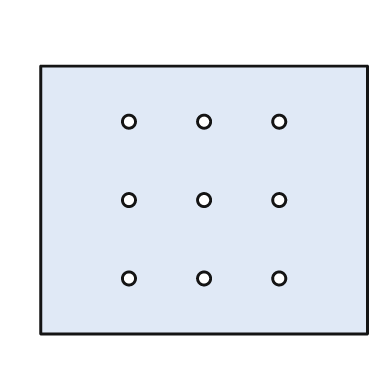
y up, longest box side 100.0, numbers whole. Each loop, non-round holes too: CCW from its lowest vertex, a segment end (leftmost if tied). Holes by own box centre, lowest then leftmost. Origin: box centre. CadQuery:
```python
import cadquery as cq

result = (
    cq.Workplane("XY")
    .moveTo(-50.0, -41.0)
    .lineTo(50.0, -41.0)
    .lineTo(50.0, 41.0)
    .lineTo(-50.0, 41.0)
    .close()
    .moveTo(-23.0, -24.0)
    .circle(2.0)
    .moveTo(0.0, -24.0)
    .circle(2.0)
    .moveTo(23.0, -24.0)
    .circle(2.0)
    .moveTo(-23.0, 0.0)
    .circle(2.0)
    .moveTo(0.0, 0.0)
    .circle(2.0)
    .moveTo(23.0, 0.0)
    .circle(2.0)
    .moveTo(-23.0, 24.0)
    .circle(2.0)
    .moveTo(0.0, 24.0)
    .circle(2.0)
    .moveTo(23.0, 24.0)
    .circle(2.0)
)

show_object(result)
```